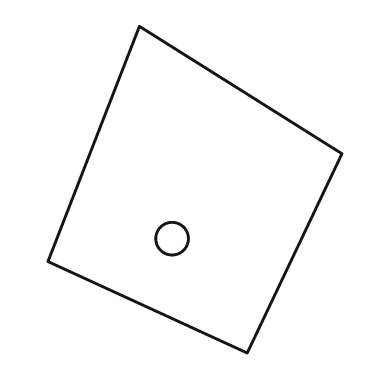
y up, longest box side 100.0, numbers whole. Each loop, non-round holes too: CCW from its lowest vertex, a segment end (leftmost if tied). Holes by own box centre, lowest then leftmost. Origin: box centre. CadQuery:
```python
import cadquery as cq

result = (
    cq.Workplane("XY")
    .moveTo(16.0, -50.0)
    .lineTo(45.0, 11.0)
    .lineTo(-17.0, 50.0)
    .lineTo(-45.0, -22.0)
    .close()
    .moveTo(-7.0, -15.0)
    .circle(5.0)
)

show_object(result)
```